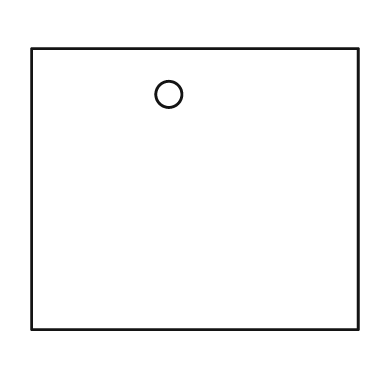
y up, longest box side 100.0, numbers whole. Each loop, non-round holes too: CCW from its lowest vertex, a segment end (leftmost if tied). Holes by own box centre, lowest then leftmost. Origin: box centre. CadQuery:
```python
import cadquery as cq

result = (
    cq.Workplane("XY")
    .moveTo(-50.0, -43.0)
    .lineTo(50.0, -43.0)
    .lineTo(50.0, 43.0)
    .lineTo(-50.0, 43.0)
    .close()
    .moveTo(-8.0, 29.0)
    .circle(4.0)
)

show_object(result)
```